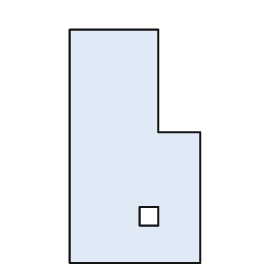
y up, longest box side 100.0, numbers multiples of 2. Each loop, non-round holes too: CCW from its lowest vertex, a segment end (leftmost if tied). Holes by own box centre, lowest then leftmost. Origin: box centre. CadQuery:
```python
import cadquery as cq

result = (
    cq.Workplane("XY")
    .moveTo(-28.0, -50.0)
    .lineTo(28.0, -50.0)
    .lineTo(28.0, 6.0)
    .lineTo(10.0, 6.0)
    .lineTo(10.0, 50.0)
    .lineTo(-28.0, 50.0)
    .close()
    .moveTo(2.0, -34.0)
    .lineTo(10.0, -34.0)
    .lineTo(10.0, -26.0)
    .lineTo(2.0, -26.0)
    .close()
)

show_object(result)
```